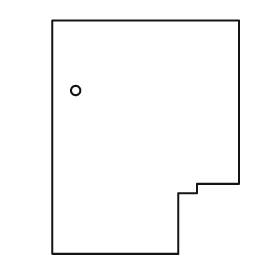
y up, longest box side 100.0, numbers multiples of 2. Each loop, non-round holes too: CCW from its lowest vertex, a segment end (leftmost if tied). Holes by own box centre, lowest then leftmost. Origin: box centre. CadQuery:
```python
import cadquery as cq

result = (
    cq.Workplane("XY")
    .moveTo(-40.0, -50.0)
    .lineTo(14.0, -50.0)
    .lineTo(14.0, -24.0)
    .lineTo(22.0, -24.0)
    .lineTo(22.0, -20.0)
    .lineTo(40.0, -20.0)
    .lineTo(40.0, 50.0)
    .lineTo(-40.0, 50.0)
    .close()
    .moveTo(-30.0, 20.0)
    .circle(2.0)
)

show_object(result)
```